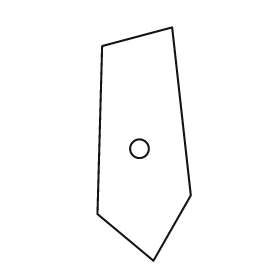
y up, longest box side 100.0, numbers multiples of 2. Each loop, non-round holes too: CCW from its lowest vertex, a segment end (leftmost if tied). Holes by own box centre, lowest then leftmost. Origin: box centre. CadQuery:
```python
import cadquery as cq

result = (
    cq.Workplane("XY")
    .moveTo(4.0, -50.0)
    .lineTo(20.0, -22.0)
    .lineTo(12.0, 50.0)
    .lineTo(-18.0, 42.0)
    .lineTo(-20.0, -30.0)
    .close()
    .moveTo(-2.0, -2.0)
    .circle(4.0)
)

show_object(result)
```